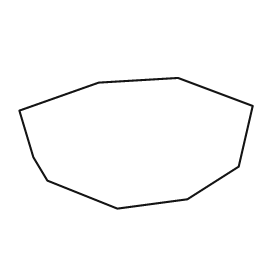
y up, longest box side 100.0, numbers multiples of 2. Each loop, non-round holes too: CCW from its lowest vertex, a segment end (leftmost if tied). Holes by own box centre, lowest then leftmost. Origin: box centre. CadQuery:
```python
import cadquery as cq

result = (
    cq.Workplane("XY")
    .moveTo(-8.0, -28.0)
    .lineTo(22.0, -24.0)
    .lineTo(44.0, -10.0)
    .lineTo(50.0, 16.0)
    .lineTo(18.0, 28.0)
    .lineTo(-16.0, 26.0)
    .lineTo(-50.0, 14.0)
    .lineTo(-44.0, -6.0)
    .lineTo(-38.0, -16.0)
    .close()
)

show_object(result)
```